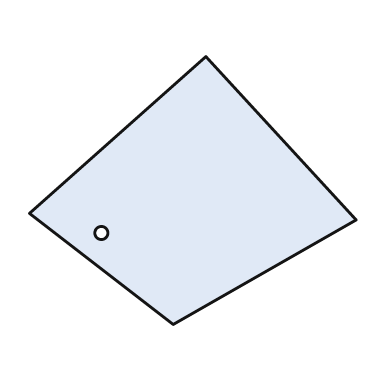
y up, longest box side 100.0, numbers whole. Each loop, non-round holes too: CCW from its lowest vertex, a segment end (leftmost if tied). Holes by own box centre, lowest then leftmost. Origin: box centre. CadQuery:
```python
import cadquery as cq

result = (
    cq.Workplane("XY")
    .moveTo(-6.0, -41.0)
    .lineTo(50.0, -9.0)
    .lineTo(4.0, 41.0)
    .lineTo(-50.0, -7.0)
    .close()
    .moveTo(-28.0, -13.0)
    .circle(2.0)
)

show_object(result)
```